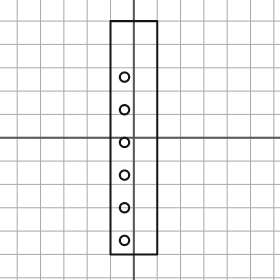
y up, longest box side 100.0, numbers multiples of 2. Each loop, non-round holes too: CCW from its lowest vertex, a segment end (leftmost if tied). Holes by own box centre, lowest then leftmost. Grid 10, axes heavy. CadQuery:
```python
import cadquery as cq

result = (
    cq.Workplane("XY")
    .moveTo(-10.0, -50.0)
    .lineTo(10.0, -50.0)
    .lineTo(10.0, 50.0)
    .lineTo(-10.0, 50.0)
    .close()
    .moveTo(-4.0, -44.0)
    .circle(2.0)
    .moveTo(-4.0, -30.0)
    .circle(2.0)
    .moveTo(-4.0, -16.0)
    .circle(2.0)
    .moveTo(-4.0, -2.0)
    .circle(2.0)
    .moveTo(-4.0, 12.0)
    .circle(2.0)
    .moveTo(-4.0, 26.0)
    .circle(2.0)
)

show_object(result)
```